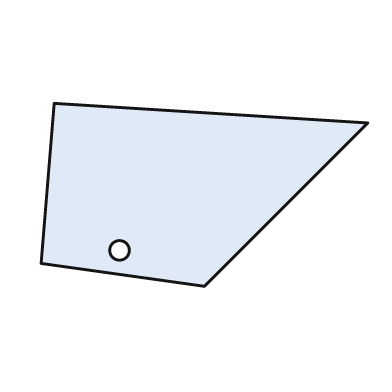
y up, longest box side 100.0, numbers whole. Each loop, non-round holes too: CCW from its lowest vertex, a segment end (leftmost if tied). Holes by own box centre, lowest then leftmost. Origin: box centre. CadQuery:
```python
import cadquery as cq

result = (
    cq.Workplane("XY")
    .moveTo(0.0, -28.0)
    .lineTo(50.0, 22.0)
    .lineTo(-46.0, 28.0)
    .lineTo(-50.0, -21.0)
    .close()
    .moveTo(-26.0, -17.0)
    .circle(3.0)
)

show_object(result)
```